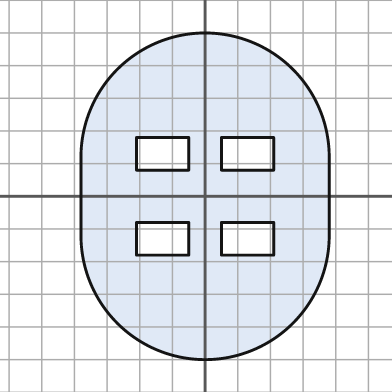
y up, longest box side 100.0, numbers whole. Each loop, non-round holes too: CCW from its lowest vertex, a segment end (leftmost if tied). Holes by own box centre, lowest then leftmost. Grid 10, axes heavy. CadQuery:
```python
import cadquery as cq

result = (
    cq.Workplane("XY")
    .moveTo(-38.0, -12.0)
    .threePointArc((0.0, -50.0), (38.0, -12.0))
    .lineTo(38.0, 12.0)
    .threePointArc((0.0, 50.0), (-38.0, 12.0))
    .close()
    .moveTo(-21.0, -18.0)
    .lineTo(-5.0, -18.0)
    .lineTo(-5.0, -8.0)
    .lineTo(-21.0, -8.0)
    .close()
    .moveTo(5.0, -18.0)
    .lineTo(21.0, -18.0)
    .lineTo(21.0, -8.0)
    .lineTo(5.0, -8.0)
    .close()
    .moveTo(-21.0, 8.0)
    .lineTo(-5.0, 8.0)
    .lineTo(-5.0, 18.0)
    .lineTo(-21.0, 18.0)
    .close()
    .moveTo(5.0, 8.0)
    .lineTo(21.0, 8.0)
    .lineTo(21.0, 18.0)
    .lineTo(5.0, 18.0)
    .close()
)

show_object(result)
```